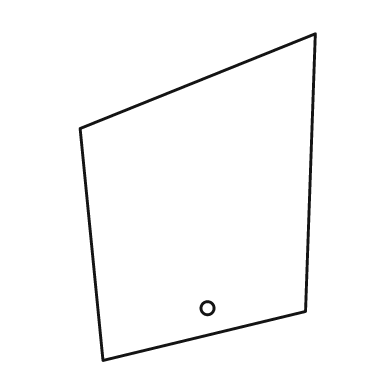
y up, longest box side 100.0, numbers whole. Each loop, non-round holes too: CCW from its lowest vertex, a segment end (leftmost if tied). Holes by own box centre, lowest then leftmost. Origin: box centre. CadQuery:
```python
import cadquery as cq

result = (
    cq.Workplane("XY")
    .moveTo(-29.0, -50.0)
    .lineTo(33.0, -35.0)
    .lineTo(36.0, 50.0)
    .lineTo(-36.0, 21.0)
    .close()
    .moveTo(3.0, -34.0)
    .circle(2.0)
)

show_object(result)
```